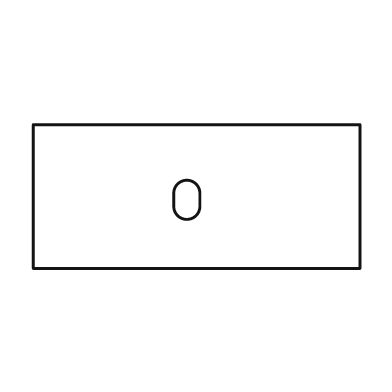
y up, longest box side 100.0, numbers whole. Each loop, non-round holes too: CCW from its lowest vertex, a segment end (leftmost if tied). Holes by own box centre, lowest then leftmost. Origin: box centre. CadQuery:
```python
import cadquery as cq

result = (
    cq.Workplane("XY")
    .moveTo(-50.0, -22.0)
    .lineTo(50.0, -22.0)
    .lineTo(50.0, 22.0)
    .lineTo(-50.0, 22.0)
    .close()
    .moveTo(-7.0, -3.0)
    .threePointArc((-3.0, -7.0), (1.0, -3.0))
    .lineTo(1.0, 1.0)
    .threePointArc((-3.0, 5.0), (-7.0, 1.0))
    .close()
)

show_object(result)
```